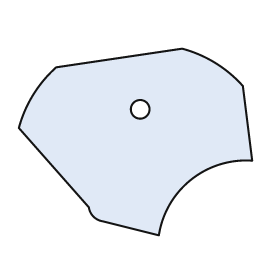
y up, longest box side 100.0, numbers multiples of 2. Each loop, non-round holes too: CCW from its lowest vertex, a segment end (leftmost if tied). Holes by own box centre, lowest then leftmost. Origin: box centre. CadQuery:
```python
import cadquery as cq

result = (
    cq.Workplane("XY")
    .moveTo(10.0, -40.0)
    .threePointArc((24.0, -16.0), (50.0, -8.0))
    .lineTo(46.0, 24.0)
    .threePointArc((34.0, 34.0), (20.0, 40.0))
    .lineTo(-34.0, 32.0)
    .threePointArc((-44.0, 20.0), (-50.0, 6.0))
    .lineTo(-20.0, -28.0)
    .threePointArc((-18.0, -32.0), (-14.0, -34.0))
    .close()
    .moveTo(2.0, 14.0)
    .circle(4.0)
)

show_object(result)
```